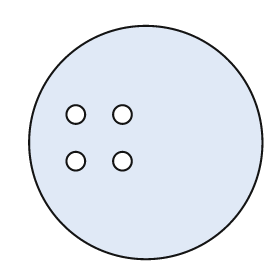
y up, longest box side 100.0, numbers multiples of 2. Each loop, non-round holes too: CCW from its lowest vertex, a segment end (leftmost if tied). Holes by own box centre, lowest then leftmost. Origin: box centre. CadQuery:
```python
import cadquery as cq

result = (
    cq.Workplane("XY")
    .moveTo(0.0, 0.0)
    .circle(50.0)
    .moveTo(-30.0, -8.0)
    .circle(4.0)
    .moveTo(-10.0, -8.0)
    .circle(4.0)
    .moveTo(-30.0, 12.0)
    .circle(4.0)
    .moveTo(-10.0, 12.0)
    .circle(4.0)
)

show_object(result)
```